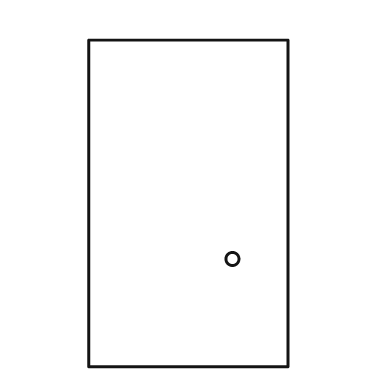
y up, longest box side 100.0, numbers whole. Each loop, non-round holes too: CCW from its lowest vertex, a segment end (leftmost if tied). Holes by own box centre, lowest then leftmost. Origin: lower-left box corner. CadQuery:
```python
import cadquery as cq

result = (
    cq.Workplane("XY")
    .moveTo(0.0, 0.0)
    .lineTo(61.0, 0.0)
    .lineTo(61.0, 100.0)
    .lineTo(0.0, 100.0)
    .close()
    .moveTo(44.0, 33.0)
    .circle(2.0)
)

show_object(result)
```